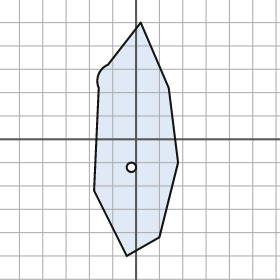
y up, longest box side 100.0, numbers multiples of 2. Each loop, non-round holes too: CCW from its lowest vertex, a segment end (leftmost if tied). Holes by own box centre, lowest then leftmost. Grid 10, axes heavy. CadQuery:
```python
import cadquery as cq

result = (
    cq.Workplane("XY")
    .moveTo(-4.0, -50.0)
    .lineTo(10.0, -42.0)
    .lineTo(18.0, -10.0)
    .lineTo(14.0, 22.0)
    .lineTo(2.0, 50.0)
    .lineTo(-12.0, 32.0)
    .threePointArc((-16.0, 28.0), (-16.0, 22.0))
    .lineTo(-18.0, -22.0)
    .close()
    .moveTo(-2.0, -12.0)
    .circle(2.0)
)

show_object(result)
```